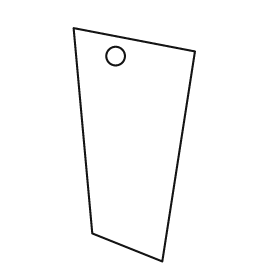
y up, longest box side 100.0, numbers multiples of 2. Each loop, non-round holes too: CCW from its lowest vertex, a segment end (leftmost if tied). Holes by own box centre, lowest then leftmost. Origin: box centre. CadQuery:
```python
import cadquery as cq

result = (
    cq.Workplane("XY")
    .moveTo(12.0, -50.0)
    .lineTo(26.0, 40.0)
    .lineTo(-26.0, 50.0)
    .lineTo(-18.0, -38.0)
    .close()
    .moveTo(-8.0, 38.0)
    .circle(4.0)
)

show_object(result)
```